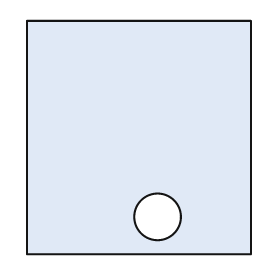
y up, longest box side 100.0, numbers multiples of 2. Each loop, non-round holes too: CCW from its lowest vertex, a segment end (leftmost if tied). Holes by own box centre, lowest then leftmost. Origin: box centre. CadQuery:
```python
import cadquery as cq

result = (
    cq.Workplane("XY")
    .moveTo(-48.0, -50.0)
    .lineTo(48.0, -50.0)
    .lineTo(48.0, 50.0)
    .lineTo(-48.0, 50.0)
    .close()
    .moveTo(8.0, -34.0)
    .circle(10.0)
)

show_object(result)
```